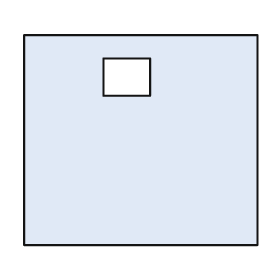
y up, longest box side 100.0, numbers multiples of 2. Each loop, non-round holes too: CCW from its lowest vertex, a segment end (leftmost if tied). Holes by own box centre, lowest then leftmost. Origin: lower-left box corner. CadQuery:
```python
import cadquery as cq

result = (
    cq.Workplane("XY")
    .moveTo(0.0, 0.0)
    .lineTo(100.0, 0.0)
    .lineTo(100.0, 90.0)
    .lineTo(0.0, 90.0)
    .close()
    .moveTo(34.0, 64.0)
    .lineTo(54.0, 64.0)
    .lineTo(54.0, 80.0)
    .lineTo(34.0, 80.0)
    .close()
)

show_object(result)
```